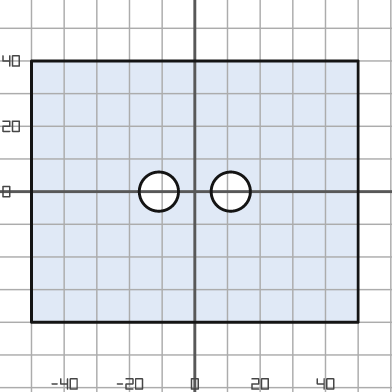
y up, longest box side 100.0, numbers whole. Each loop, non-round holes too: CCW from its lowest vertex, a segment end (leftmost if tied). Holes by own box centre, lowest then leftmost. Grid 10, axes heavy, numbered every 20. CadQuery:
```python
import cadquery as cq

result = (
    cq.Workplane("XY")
    .moveTo(-50.0, -40.0)
    .lineTo(50.0, -40.0)
    .lineTo(50.0, 40.0)
    .lineTo(-50.0, 40.0)
    .close()
    .moveTo(-11.0, 0.0)
    .circle(6.0)
    .moveTo(11.0, 0.0)
    .circle(6.0)
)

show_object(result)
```